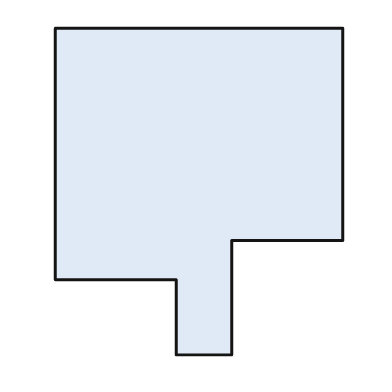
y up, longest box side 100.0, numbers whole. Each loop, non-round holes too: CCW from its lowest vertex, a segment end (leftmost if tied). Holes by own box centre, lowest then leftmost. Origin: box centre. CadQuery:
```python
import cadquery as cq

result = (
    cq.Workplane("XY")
    .moveTo(-7.0, -50.0)
    .lineTo(10.0, -50.0)
    .lineTo(10.0, -15.0)
    .lineTo(44.0, -15.0)
    .lineTo(44.0, 50.0)
    .lineTo(-44.0, 50.0)
    .lineTo(-44.0, -27.0)
    .lineTo(-7.0, -27.0)
    .close()
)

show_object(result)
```